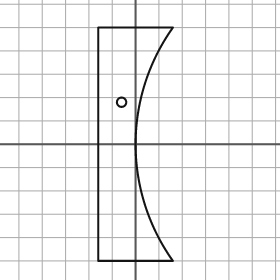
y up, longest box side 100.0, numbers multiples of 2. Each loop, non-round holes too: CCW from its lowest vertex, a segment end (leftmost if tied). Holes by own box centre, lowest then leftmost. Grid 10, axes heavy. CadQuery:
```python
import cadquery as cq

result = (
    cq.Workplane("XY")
    .moveTo(-16.0, -50.0)
    .lineTo(16.0, -50.0)
    .threePointArc((0.0, 0.0), (16.0, 50.0))
    .lineTo(-16.0, 50.0)
    .close()
    .moveTo(-6.0, 18.0)
    .circle(2.0)
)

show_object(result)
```